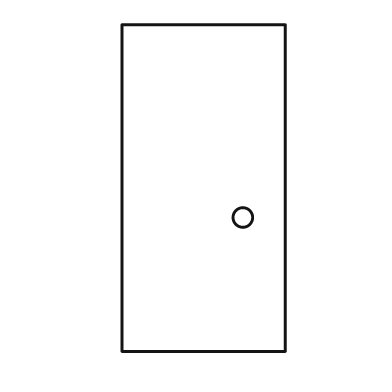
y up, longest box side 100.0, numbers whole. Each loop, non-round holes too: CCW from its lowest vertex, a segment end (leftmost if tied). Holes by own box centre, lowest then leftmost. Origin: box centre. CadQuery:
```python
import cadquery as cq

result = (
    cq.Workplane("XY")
    .moveTo(-25.0, -50.0)
    .lineTo(25.0, -50.0)
    .lineTo(25.0, 50.0)
    .lineTo(-25.0, 50.0)
    .close()
    .moveTo(12.0, -9.0)
    .circle(3.0)
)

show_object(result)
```